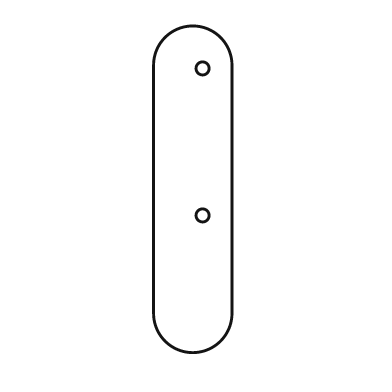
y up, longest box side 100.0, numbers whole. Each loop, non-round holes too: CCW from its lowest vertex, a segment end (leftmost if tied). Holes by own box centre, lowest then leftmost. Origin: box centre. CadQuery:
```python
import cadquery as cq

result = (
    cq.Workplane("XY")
    .moveTo(-12.0, -38.0)
    .threePointArc((0.0, -50.0), (12.0, -38.0))
    .lineTo(12.0, 38.0)
    .threePointArc((0.0, 50.0), (-12.0, 38.0))
    .close()
    .moveTo(3.0, -8.0)
    .circle(2.0)
    .moveTo(3.0, 37.0)
    .circle(2.0)
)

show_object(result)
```